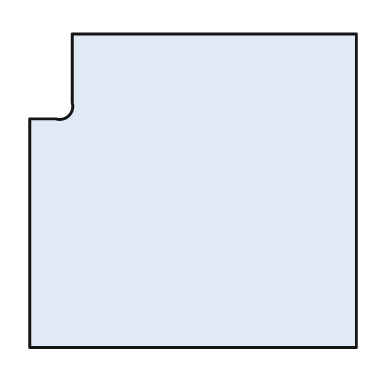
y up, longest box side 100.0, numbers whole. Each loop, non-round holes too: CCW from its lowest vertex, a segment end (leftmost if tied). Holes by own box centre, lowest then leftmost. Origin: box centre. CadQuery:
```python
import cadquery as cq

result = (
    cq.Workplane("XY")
    .moveTo(-50.0, -48.0)
    .lineTo(50.0, -48.0)
    .lineTo(50.0, 48.0)
    .lineTo(-37.0, 48.0)
    .lineTo(-37.0, 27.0)
    .threePointArc((-38.0, 23.0), (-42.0, 22.0))
    .lineTo(-50.0, 22.0)
    .close()
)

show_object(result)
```